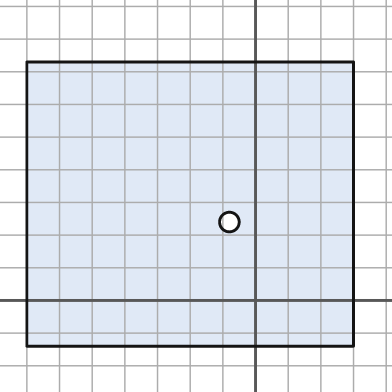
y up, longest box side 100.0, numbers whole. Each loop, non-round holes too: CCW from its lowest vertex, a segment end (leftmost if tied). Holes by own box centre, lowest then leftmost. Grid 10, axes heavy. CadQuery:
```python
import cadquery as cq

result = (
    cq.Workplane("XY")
    .moveTo(-70.0, -14.0)
    .lineTo(30.0, -14.0)
    .lineTo(30.0, 73.0)
    .lineTo(-70.0, 73.0)
    .close()
    .moveTo(-8.0, 24.0)
    .circle(3.0)
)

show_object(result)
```